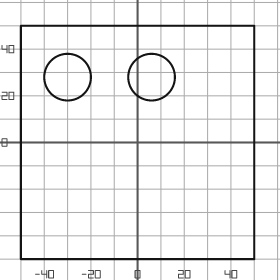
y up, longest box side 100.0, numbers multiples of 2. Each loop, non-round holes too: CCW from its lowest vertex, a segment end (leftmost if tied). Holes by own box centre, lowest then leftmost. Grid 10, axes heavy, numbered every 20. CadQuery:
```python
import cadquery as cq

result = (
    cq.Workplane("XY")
    .moveTo(-50.0, -50.0)
    .lineTo(50.0, -50.0)
    .lineTo(50.0, 50.0)
    .lineTo(-50.0, 50.0)
    .close()
    .moveTo(-30.0, 28.0)
    .circle(10.0)
    .moveTo(6.0, 28.0)
    .circle(10.0)
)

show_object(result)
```